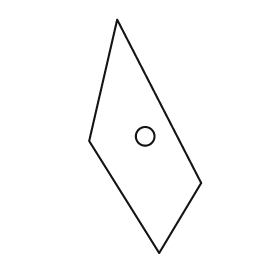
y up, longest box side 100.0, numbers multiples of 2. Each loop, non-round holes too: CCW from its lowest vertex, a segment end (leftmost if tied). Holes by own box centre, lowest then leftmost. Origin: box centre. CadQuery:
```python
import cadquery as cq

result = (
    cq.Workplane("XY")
    .moveTo(6.0, -50.0)
    .lineTo(24.0, -20.0)
    .lineTo(-12.0, 50.0)
    .lineTo(-24.0, -2.0)
    .close()
    .moveTo(0.0, 0.0)
    .circle(4.0)
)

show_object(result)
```